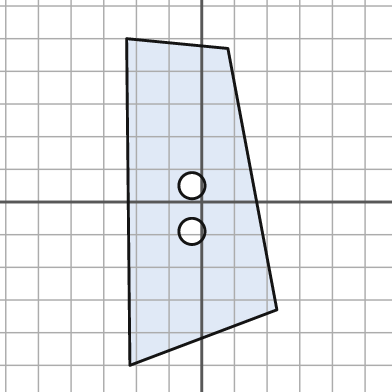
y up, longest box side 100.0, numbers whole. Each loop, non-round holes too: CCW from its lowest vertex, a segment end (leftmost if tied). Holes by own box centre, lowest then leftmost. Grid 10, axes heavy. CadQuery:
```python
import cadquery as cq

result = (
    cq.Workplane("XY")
    .moveTo(-22.0, -50.0)
    .lineTo(23.0, -33.0)
    .lineTo(8.0, 47.0)
    .lineTo(-23.0, 50.0)
    .close()
    .moveTo(-3.0, -9.0)
    .circle(4.0)
    .moveTo(-3.0, 5.0)
    .circle(4.0)
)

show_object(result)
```